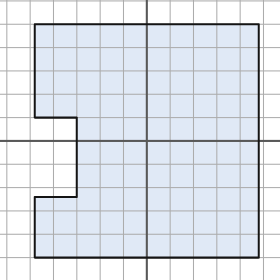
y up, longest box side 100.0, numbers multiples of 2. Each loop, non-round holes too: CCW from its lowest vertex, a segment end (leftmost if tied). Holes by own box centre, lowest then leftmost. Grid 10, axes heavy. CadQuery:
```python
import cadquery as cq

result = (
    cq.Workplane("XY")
    .moveTo(-48.0, -50.0)
    .lineTo(48.0, -50.0)
    .lineTo(48.0, 50.0)
    .lineTo(-48.0, 50.0)
    .lineTo(-48.0, 10.0)
    .lineTo(-30.0, 10.0)
    .lineTo(-30.0, -24.0)
    .lineTo(-48.0, -24.0)
    .close()
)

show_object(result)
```